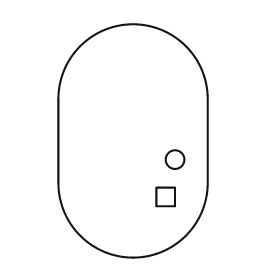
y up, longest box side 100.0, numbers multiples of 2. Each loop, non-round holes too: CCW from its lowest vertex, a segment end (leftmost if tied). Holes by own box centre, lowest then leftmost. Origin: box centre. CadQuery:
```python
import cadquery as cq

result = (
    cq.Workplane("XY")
    .moveTo(-32.0, -18.0)
    .threePointArc((0.0, -50.0), (32.0, -18.0))
    .lineTo(32.0, 18.0)
    .threePointArc((0.0, 50.0), (-32.0, 18.0))
    .close()
    .moveTo(10.0, -28.0)
    .lineTo(18.0, -28.0)
    .lineTo(18.0, -20.0)
    .lineTo(10.0, -20.0)
    .close()
    .moveTo(18.0, -8.0)
    .circle(4.0)
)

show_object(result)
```